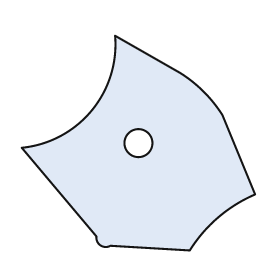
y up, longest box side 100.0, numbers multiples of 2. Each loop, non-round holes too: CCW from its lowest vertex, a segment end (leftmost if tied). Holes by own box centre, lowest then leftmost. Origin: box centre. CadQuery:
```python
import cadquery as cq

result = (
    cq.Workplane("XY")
    .moveTo(22.0, -46.0)
    .threePointArc((34.0, -32.0), (50.0, -22.0))
    .lineTo(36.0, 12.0)
    .threePointArc((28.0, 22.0), (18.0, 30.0))
    .lineTo(-10.0, 46.0)
    .threePointArc((-20.0, 14.0), (-50.0, -2.0))
    .lineTo(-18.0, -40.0)
    .threePointArc((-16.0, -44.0), (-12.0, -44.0))
    .close()
    .moveTo(0.0, 0.0)
    .circle(6.0)
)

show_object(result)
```